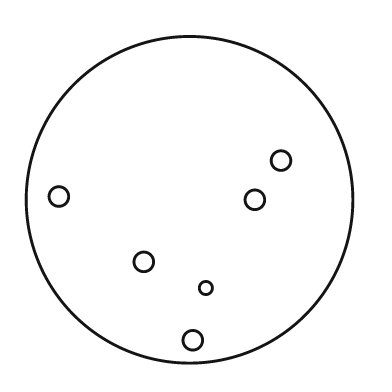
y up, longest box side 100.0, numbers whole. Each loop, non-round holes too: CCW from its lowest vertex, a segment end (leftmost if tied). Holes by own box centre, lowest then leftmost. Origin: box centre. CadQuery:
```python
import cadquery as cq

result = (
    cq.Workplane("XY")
    .moveTo(0.0, 0.0)
    .circle(50.0)
    .moveTo(1.0, -43.0)
    .circle(3.0)
    .moveTo(5.0, -27.0)
    .circle(2.0)
    .moveTo(-14.0, -19.0)
    .circle(3.0)
    .moveTo(20.0, 0.0)
    .circle(3.0)
    .moveTo(-40.0, 1.0)
    .circle(3.0)
    .moveTo(28.0, 12.0)
    .circle(3.0)
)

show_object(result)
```